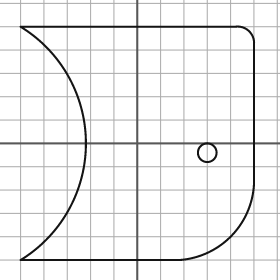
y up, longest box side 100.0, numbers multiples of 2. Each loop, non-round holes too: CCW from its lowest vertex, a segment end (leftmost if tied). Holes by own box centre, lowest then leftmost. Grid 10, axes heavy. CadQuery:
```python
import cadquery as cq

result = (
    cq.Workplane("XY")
    .moveTo(-50.0, -50.0)
    .lineTo(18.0, -50.0)
    .threePointArc((40.0, -40.0), (50.0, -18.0))
    .lineTo(50.0, 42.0)
    .threePointArc((48.0, 48.0), (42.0, 50.0))
    .lineTo(-50.0, 50.0)
    .threePointArc((-22.0, 0.0), (-50.0, -50.0))
    .close()
    .moveTo(30.0, -4.0)
    .circle(4.0)
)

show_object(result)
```